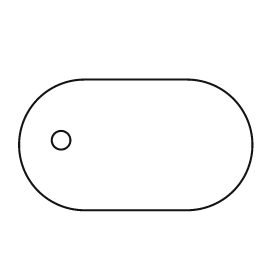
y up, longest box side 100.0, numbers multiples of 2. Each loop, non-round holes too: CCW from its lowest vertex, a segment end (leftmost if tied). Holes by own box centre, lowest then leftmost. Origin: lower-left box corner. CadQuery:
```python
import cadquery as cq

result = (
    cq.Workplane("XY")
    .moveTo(28.0, 0.0)
    .lineTo(72.0, 0.0)
    .threePointArc((100.0, 28.0), (72.0, 56.0))
    .lineTo(28.0, 56.0)
    .threePointArc((0.0, 28.0), (28.0, 0.0))
    .close()
    .moveTo(18.0, 30.0)
    .circle(4.0)
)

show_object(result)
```